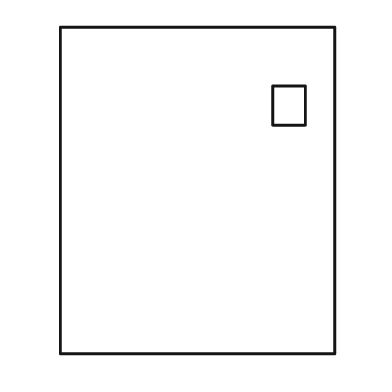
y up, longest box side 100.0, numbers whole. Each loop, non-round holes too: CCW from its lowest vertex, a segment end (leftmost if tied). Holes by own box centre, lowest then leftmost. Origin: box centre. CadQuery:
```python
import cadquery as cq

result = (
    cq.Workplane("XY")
    .moveTo(-42.0, -50.0)
    .lineTo(42.0, -50.0)
    .lineTo(42.0, 50.0)
    .lineTo(-42.0, 50.0)
    .close()
    .moveTo(23.0, 20.0)
    .lineTo(33.0, 20.0)
    .lineTo(33.0, 32.0)
    .lineTo(23.0, 32.0)
    .close()
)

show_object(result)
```